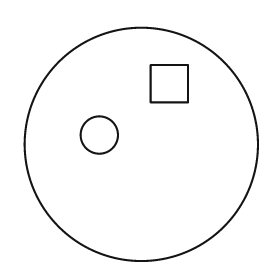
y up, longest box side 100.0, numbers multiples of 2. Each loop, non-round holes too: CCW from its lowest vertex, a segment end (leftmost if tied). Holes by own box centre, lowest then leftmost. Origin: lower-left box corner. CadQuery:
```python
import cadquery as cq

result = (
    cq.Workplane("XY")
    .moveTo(50.0, 50.0)
    .circle(50.0)
    .moveTo(32.0, 54.0)
    .circle(8.0)
    .moveTo(54.0, 68.0)
    .lineTo(70.0, 68.0)
    .lineTo(70.0, 84.0)
    .lineTo(54.0, 84.0)
    .close()
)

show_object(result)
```